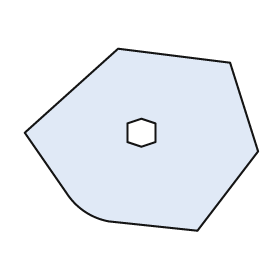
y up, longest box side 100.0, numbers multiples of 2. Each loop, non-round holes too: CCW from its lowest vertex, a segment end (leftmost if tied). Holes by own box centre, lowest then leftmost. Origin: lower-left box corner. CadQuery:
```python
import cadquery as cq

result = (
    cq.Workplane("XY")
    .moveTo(74.0, 0.0)
    .lineTo(100.0, 34.0)
    .lineTo(88.0, 72.0)
    .lineTo(40.0, 78.0)
    .lineTo(0.0, 42.0)
    .lineTo(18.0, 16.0)
    .threePointArc((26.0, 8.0), (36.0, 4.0))
    .close()
    .moveTo(50.0, 36.0)
    .lineTo(56.0, 38.0)
    .lineTo(56.0, 46.0)
    .lineTo(50.0, 48.0)
    .lineTo(44.0, 46.0)
    .lineTo(44.0, 38.0)
    .close()
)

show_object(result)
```